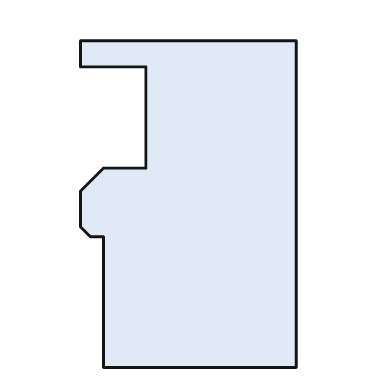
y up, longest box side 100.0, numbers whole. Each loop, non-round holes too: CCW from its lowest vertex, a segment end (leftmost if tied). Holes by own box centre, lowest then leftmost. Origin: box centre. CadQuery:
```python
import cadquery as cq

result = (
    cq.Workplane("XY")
    .moveTo(-26.0, -50.0)
    .lineTo(33.0, -50.0)
    .lineTo(33.0, 50.0)
    .lineTo(-33.0, 50.0)
    .lineTo(-33.0, 42.0)
    .lineTo(-13.0, 42.0)
    .lineTo(-13.0, 11.0)
    .lineTo(-26.0, 11.0)
    .lineTo(-33.0, 4.0)
    .lineTo(-33.0, -7.0)
    .lineTo(-30.0, -10.0)
    .lineTo(-26.0, -10.0)
    .close()
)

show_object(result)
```